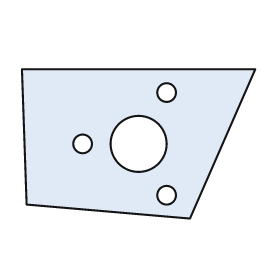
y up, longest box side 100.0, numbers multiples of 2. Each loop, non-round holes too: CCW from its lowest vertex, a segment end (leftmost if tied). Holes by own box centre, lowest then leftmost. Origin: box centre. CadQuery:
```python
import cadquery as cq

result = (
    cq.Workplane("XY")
    .moveTo(22.0, -32.0)
    .lineTo(50.0, 32.0)
    .lineTo(-50.0, 32.0)
    .lineTo(-48.0, -26.0)
    .close()
    .moveTo(12.0, -22.0)
    .circle(4.0)
    .moveTo(-24.0, 0.0)
    .circle(4.0)
    .moveTo(0.0, 0.0)
    .circle(12.0)
    .moveTo(12.0, 22.0)
    .circle(4.0)
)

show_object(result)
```